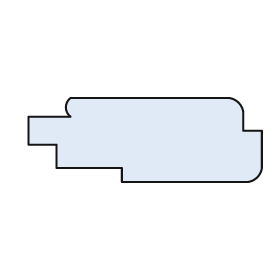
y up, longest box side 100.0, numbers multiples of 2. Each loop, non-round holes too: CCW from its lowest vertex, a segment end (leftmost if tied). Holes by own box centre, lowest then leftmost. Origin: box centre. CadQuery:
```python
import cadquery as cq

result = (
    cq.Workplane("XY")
    .moveTo(-10.0, -18.0)
    .lineTo(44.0, -18.0)
    .threePointArc((48.0, -16.0), (50.0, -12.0))
    .lineTo(50.0, 4.0)
    .lineTo(42.0, 4.0)
    .lineTo(42.0, 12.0)
    .threePointArc((40.0, 16.0), (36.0, 18.0))
    .lineTo(-32.0, 18.0)
    .threePointArc((-34.0, 14.0), (-32.0, 10.0))
    .lineTo(-50.0, 10.0)
    .lineTo(-50.0, -2.0)
    .lineTo(-38.0, -2.0)
    .lineTo(-38.0, -12.0)
    .lineTo(-10.0, -12.0)
    .close()
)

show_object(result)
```